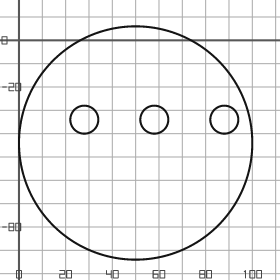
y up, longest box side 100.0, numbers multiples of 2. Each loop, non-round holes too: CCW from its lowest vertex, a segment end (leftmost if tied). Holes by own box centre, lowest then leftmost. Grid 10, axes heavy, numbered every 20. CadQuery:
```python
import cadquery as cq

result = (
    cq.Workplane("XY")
    .moveTo(50.0, -44.0)
    .circle(50.0)
    .moveTo(28.0, -34.0)
    .circle(6.0)
    .moveTo(58.0, -34.0)
    .circle(6.0)
    .moveTo(88.0, -34.0)
    .circle(6.0)
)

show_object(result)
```